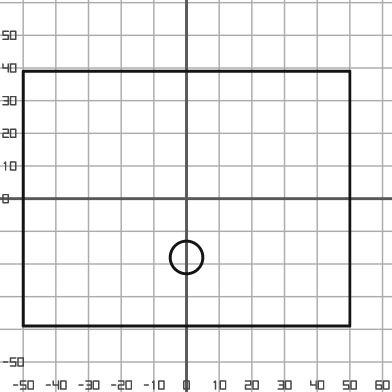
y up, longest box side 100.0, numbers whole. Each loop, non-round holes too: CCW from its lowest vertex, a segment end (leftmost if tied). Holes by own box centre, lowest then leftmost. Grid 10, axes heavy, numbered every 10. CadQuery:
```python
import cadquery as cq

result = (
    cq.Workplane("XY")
    .moveTo(-50.0, -39.0)
    .lineTo(50.0, -39.0)
    .lineTo(50.0, 39.0)
    .lineTo(-50.0, 39.0)
    .close()
    .moveTo(0.0, -18.0)
    .circle(5.0)
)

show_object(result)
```